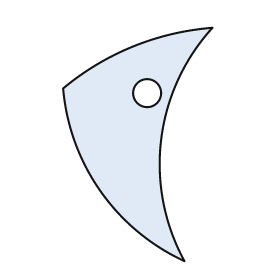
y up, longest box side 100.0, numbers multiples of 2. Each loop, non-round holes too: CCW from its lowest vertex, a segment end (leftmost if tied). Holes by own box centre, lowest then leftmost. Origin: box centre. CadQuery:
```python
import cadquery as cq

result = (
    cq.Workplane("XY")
    .moveTo(20.0, -50.0)
    .threePointArc((10.0, 2.0), (32.0, 50.0))
    .threePointArc((-2.0, 42.0), (-32.0, 24.0))
    .threePointArc((-16.0, -20.0), (20.0, -50.0))
    .close()
    .moveTo(4.0, 22.0)
    .circle(6.0)
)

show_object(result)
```